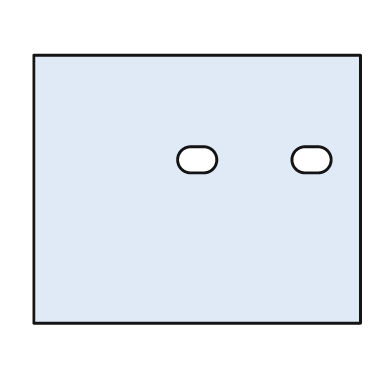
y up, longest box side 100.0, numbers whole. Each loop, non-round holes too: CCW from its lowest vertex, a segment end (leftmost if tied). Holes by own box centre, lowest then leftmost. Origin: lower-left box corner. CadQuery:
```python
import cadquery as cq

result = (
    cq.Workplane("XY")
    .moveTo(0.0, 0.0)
    .lineTo(100.0, 0.0)
    .lineTo(100.0, 82.0)
    .lineTo(0.0, 82.0)
    .close()
    .moveTo(48.0, 46.0)
    .lineTo(52.0, 46.0)
    .threePointArc((56.0, 50.0), (52.0, 54.0))
    .lineTo(48.0, 54.0)
    .threePointArc((44.0, 50.0), (48.0, 46.0))
    .close()
    .moveTo(83.0, 46.0)
    .lineTo(87.0, 46.0)
    .threePointArc((91.0, 50.0), (87.0, 54.0))
    .lineTo(83.0, 54.0)
    .threePointArc((79.0, 50.0), (83.0, 46.0))
    .close()
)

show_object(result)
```